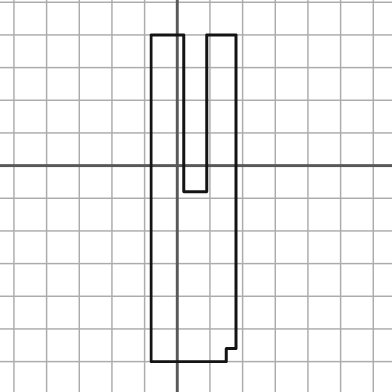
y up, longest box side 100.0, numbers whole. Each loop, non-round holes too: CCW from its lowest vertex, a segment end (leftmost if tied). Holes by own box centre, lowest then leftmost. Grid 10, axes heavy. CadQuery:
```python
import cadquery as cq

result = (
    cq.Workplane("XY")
    .moveTo(-8.0, -60.0)
    .lineTo(15.0, -60.0)
    .lineTo(15.0, -56.0)
    .lineTo(18.0, -56.0)
    .lineTo(18.0, 40.0)
    .lineTo(9.0, 40.0)
    .lineTo(9.0, -8.0)
    .lineTo(2.0, -8.0)
    .lineTo(2.0, 40.0)
    .lineTo(-8.0, 40.0)
    .close()
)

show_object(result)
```